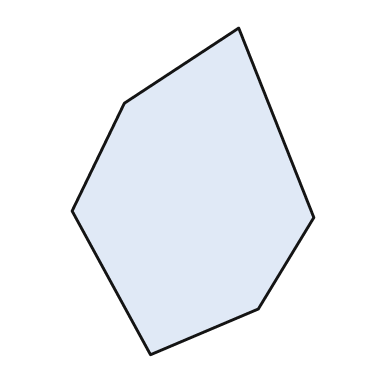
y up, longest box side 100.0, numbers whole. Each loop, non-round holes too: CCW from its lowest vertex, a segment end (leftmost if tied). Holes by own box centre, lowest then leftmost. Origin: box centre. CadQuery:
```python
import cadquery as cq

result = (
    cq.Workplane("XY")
    .moveTo(-13.0, -50.0)
    .lineTo(20.0, -36.0)
    .lineTo(37.0, -8.0)
    .lineTo(14.0, 50.0)
    .lineTo(-21.0, 27.0)
    .lineTo(-37.0, -6.0)
    .close()
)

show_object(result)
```